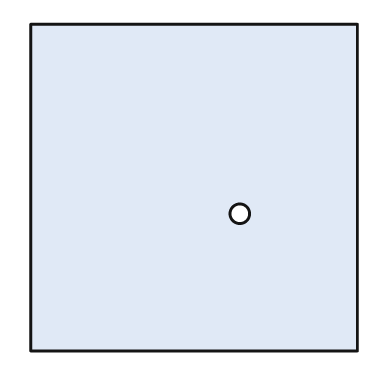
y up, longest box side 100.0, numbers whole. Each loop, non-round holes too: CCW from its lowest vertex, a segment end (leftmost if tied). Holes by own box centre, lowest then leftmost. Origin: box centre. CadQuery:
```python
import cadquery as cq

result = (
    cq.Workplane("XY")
    .moveTo(-50.0, -50.0)
    .lineTo(50.0, -50.0)
    .lineTo(50.0, 50.0)
    .lineTo(-50.0, 50.0)
    .close()
    .moveTo(14.0, -8.0)
    .circle(3.0)
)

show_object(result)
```